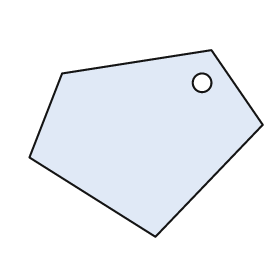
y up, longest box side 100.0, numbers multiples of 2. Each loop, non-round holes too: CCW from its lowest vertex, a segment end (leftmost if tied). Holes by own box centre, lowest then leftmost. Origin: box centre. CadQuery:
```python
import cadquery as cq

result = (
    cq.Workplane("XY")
    .moveTo(4.0, -40.0)
    .lineTo(50.0, 8.0)
    .lineTo(28.0, 40.0)
    .lineTo(-36.0, 30.0)
    .lineTo(-50.0, -6.0)
    .close()
    .moveTo(24.0, 26.0)
    .circle(4.0)
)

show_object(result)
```